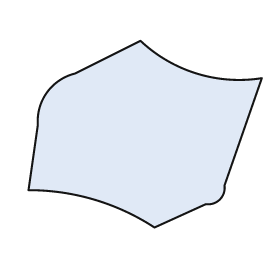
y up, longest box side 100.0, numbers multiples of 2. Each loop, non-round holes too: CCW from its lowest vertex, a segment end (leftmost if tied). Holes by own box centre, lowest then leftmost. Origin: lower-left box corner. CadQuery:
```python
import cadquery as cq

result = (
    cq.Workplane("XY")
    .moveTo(54.0, 0.0)
    .lineTo(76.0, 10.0)
    .threePointArc((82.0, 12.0), (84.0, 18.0))
    .lineTo(100.0, 64.0)
    .threePointArc((72.0, 66.0), (48.0, 80.0))
    .lineTo(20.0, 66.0)
    .threePointArc((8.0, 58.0), (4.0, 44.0))
    .lineTo(0.0, 16.0)
    .threePointArc((28.0, 12.0), (54.0, 0.0))
    .close()
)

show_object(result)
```